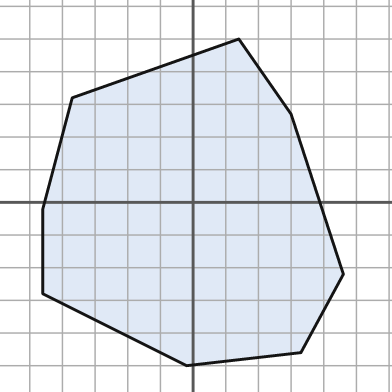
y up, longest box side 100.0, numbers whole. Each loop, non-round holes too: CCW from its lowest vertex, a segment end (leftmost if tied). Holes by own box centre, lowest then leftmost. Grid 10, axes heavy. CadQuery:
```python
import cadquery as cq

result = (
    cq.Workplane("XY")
    .moveTo(-2.0, -50.0)
    .lineTo(33.0, -46.0)
    .lineTo(46.0, -22.0)
    .lineTo(30.0, 27.0)
    .lineTo(14.0, 50.0)
    .lineTo(-37.0, 32.0)
    .lineTo(-46.0, -2.0)
    .lineTo(-46.0, -28.0)
    .close()
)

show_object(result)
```